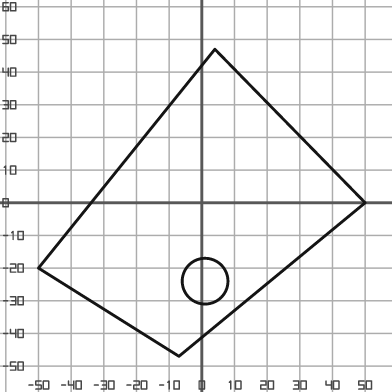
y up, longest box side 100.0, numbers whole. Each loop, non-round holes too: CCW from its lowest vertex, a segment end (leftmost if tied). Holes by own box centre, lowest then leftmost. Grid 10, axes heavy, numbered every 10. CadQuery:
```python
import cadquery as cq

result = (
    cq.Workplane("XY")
    .moveTo(-7.0, -47.0)
    .lineTo(50.0, 0.0)
    .lineTo(4.0, 47.0)
    .lineTo(-50.0, -20.0)
    .close()
    .moveTo(1.0, -24.0)
    .circle(7.0)
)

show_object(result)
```